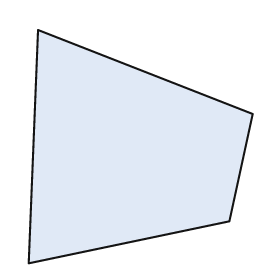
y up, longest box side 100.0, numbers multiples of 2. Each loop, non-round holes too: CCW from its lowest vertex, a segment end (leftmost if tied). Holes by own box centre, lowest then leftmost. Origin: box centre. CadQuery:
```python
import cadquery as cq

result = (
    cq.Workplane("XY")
    .moveTo(-48.0, -50.0)
    .lineTo(38.0, -32.0)
    .lineTo(48.0, 14.0)
    .lineTo(-44.0, 50.0)
    .close()
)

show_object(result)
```